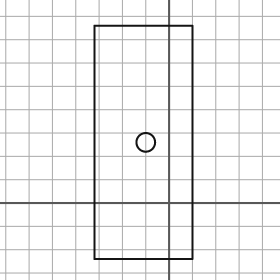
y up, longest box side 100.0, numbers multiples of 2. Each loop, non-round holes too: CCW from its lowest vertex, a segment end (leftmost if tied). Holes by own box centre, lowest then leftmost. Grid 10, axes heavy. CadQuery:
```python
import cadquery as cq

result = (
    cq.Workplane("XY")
    .moveTo(-32.0, -24.0)
    .lineTo(10.0, -24.0)
    .lineTo(10.0, 76.0)
    .lineTo(-32.0, 76.0)
    .close()
    .moveTo(-10.0, 26.0)
    .circle(4.0)
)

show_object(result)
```